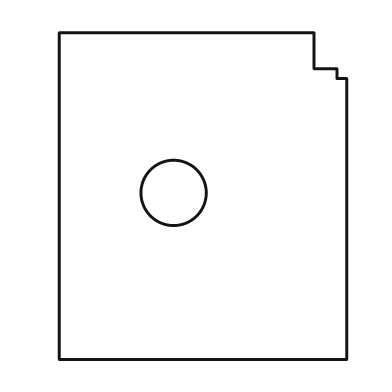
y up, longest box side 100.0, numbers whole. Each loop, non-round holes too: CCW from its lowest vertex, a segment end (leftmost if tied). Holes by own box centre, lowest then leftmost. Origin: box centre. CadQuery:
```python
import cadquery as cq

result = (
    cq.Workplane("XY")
    .moveTo(-44.0, -50.0)
    .lineTo(44.0, -50.0)
    .lineTo(44.0, 36.0)
    .lineTo(41.0, 36.0)
    .lineTo(41.0, 39.0)
    .lineTo(34.0, 39.0)
    .lineTo(34.0, 50.0)
    .lineTo(-44.0, 50.0)
    .close()
    .moveTo(-9.0, 1.0)
    .circle(10.0)
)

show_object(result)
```